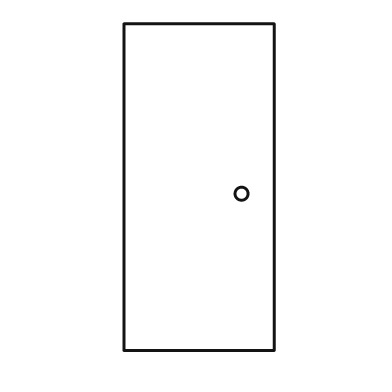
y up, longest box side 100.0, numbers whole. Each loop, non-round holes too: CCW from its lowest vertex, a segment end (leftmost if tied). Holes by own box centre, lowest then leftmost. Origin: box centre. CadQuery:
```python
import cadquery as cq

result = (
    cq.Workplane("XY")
    .moveTo(-23.0, -50.0)
    .lineTo(23.0, -50.0)
    .lineTo(23.0, 50.0)
    .lineTo(-23.0, 50.0)
    .close()
    .moveTo(13.0, -2.0)
    .circle(2.0)
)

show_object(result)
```